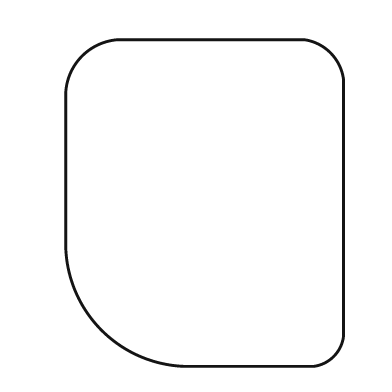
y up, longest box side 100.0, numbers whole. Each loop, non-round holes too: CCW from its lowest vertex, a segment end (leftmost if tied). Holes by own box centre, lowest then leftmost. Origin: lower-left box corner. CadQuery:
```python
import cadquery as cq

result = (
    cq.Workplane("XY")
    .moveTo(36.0, 0.0)
    .lineTo(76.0, 0.0)
    .threePointArc((82.0, 3.0), (85.0, 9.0))
    .lineTo(85.0, 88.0)
    .threePointArc((81.0, 96.0), (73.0, 100.0))
    .lineTo(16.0, 100.0)
    .threePointArc((5.0, 95.0), (0.0, 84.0))
    .lineTo(0.0, 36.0)
    .threePointArc((11.0, 11.0), (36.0, 0.0))
    .close()
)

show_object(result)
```